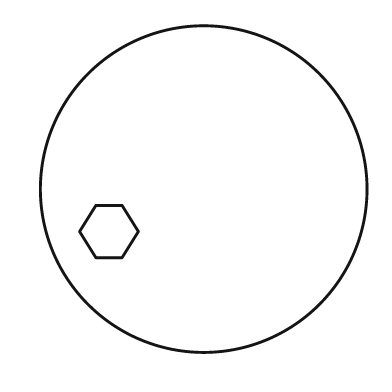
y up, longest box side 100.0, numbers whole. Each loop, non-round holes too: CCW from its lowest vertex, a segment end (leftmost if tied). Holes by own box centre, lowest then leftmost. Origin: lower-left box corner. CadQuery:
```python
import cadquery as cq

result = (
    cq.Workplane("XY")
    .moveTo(50.0, 50.0)
    .circle(50.0)
    .moveTo(17.0, 29.0)
    .lineTo(25.0, 29.0)
    .lineTo(30.0, 37.0)
    .lineTo(25.0, 45.0)
    .lineTo(17.0, 45.0)
    .lineTo(12.0, 37.0)
    .close()
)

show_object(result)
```